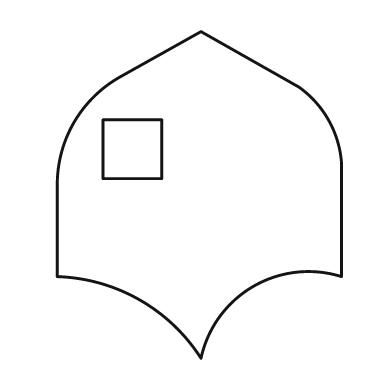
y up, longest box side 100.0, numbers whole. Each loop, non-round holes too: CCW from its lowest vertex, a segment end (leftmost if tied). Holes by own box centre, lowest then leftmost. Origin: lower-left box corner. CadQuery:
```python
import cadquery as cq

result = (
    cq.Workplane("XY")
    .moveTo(44.0, 0.0)
    .threePointArc((60.0, 22.0), (87.0, 25.0))
    .lineTo(87.0, 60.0)
    .threePointArc((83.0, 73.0), (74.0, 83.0))
    .lineTo(44.0, 100.0)
    .lineTo(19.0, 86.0)
    .threePointArc((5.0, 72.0), (0.0, 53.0))
    .lineTo(0.0, 25.0)
    .threePointArc((25.0, 18.0), (44.0, 0.0))
    .close()
    .moveTo(14.0, 55.0)
    .lineTo(32.0, 55.0)
    .lineTo(32.0, 73.0)
    .lineTo(14.0, 73.0)
    .close()
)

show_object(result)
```